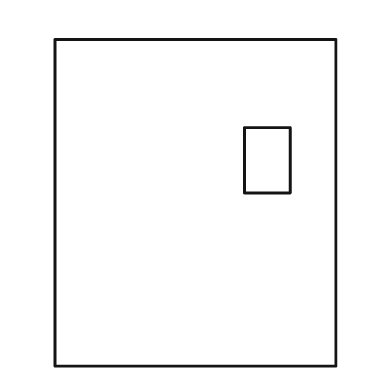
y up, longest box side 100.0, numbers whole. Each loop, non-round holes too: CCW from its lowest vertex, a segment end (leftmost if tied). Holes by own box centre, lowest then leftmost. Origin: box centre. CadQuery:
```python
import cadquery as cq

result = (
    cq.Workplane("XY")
    .moveTo(-43.0, -50.0)
    .lineTo(43.0, -50.0)
    .lineTo(43.0, 50.0)
    .lineTo(-43.0, 50.0)
    .close()
    .moveTo(15.0, 3.0)
    .lineTo(29.0, 3.0)
    .lineTo(29.0, 23.0)
    .lineTo(15.0, 23.0)
    .close()
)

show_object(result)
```